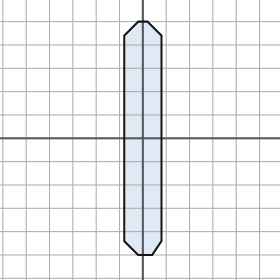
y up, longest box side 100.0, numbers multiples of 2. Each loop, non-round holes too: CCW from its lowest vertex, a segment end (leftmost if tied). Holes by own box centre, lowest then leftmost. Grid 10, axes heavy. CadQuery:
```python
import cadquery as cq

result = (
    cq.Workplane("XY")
    .moveTo(-2.0, -50.0)
    .lineTo(4.0, -50.0)
    .lineTo(8.0, -44.0)
    .lineTo(8.0, 44.0)
    .lineTo(2.0, 50.0)
    .lineTo(-2.0, 50.0)
    .lineTo(-8.0, 44.0)
    .lineTo(-8.0, -44.0)
    .close()
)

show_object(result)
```